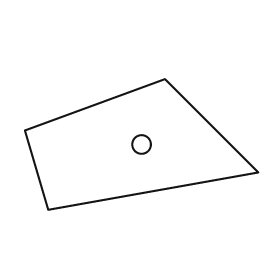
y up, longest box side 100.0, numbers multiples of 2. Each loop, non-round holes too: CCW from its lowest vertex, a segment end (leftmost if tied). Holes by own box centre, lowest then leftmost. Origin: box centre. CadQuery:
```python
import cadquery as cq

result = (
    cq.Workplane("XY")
    .moveTo(-40.0, -28.0)
    .lineTo(50.0, -12.0)
    .lineTo(10.0, 28.0)
    .lineTo(-50.0, 6.0)
    .close()
    .moveTo(0.0, 0.0)
    .circle(4.0)
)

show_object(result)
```